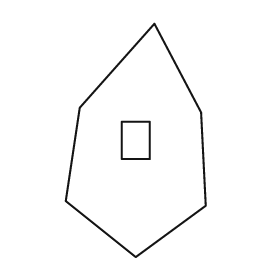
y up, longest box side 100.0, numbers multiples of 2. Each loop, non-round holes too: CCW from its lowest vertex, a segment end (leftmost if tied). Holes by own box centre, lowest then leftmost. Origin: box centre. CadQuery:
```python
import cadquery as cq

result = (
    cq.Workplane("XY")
    .moveTo(0.0, -50.0)
    .lineTo(30.0, -28.0)
    .lineTo(28.0, 12.0)
    .lineTo(8.0, 50.0)
    .lineTo(-24.0, 14.0)
    .lineTo(-30.0, -26.0)
    .close()
    .moveTo(-6.0, -8.0)
    .lineTo(6.0, -8.0)
    .lineTo(6.0, 8.0)
    .lineTo(-6.0, 8.0)
    .close()
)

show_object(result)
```